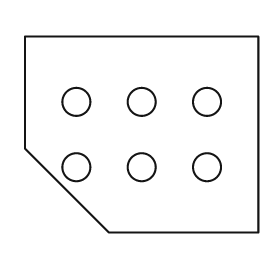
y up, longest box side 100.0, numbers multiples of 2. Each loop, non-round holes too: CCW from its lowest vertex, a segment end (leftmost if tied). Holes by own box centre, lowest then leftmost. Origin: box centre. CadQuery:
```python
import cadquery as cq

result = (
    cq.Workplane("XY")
    .moveTo(-14.0, -42.0)
    .lineTo(50.0, -42.0)
    .lineTo(50.0, 42.0)
    .lineTo(-50.0, 42.0)
    .lineTo(-50.0, -6.0)
    .close()
    .moveTo(-28.0, -14.0)
    .circle(6.0)
    .moveTo(0.0, -14.0)
    .circle(6.0)
    .moveTo(28.0, -14.0)
    .circle(6.0)
    .moveTo(-28.0, 14.0)
    .circle(6.0)
    .moveTo(0.0, 14.0)
    .circle(6.0)
    .moveTo(28.0, 14.0)
    .circle(6.0)
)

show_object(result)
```